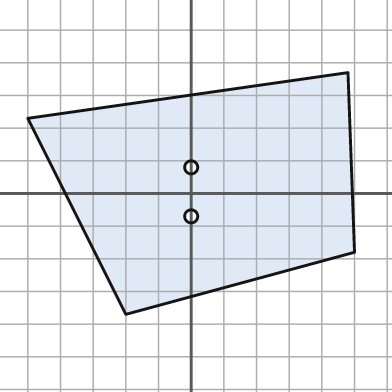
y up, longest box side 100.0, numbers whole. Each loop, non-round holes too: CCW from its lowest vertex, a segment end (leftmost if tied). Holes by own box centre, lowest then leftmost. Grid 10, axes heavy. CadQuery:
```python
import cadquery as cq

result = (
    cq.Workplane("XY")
    .moveTo(-20.0, -37.0)
    .lineTo(50.0, -18.0)
    .lineTo(48.0, 37.0)
    .lineTo(-50.0, 23.0)
    .close()
    .moveTo(0.0, -7.0)
    .circle(2.0)
    .moveTo(0.0, 8.0)
    .circle(2.0)
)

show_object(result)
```